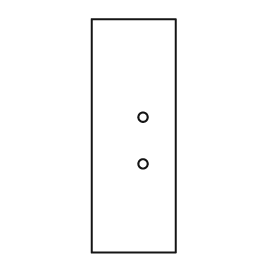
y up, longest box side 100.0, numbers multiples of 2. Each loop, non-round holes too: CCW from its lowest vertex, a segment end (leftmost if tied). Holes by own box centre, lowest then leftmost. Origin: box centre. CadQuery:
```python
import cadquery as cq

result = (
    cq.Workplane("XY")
    .moveTo(-18.0, -50.0)
    .lineTo(18.0, -50.0)
    .lineTo(18.0, 50.0)
    .lineTo(-18.0, 50.0)
    .close()
    .moveTo(4.0, -12.0)
    .circle(2.0)
    .moveTo(4.0, 8.0)
    .circle(2.0)
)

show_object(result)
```